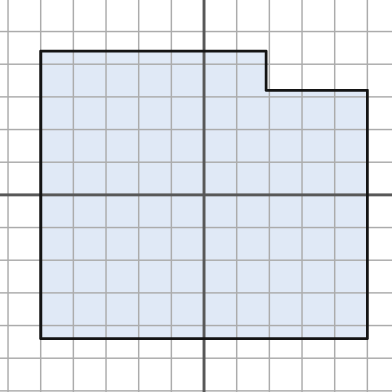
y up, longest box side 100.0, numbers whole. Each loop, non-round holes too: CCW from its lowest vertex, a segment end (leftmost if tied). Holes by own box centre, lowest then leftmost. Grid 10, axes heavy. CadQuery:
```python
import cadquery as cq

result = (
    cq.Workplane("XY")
    .moveTo(-50.0, -44.0)
    .lineTo(50.0, -44.0)
    .lineTo(50.0, 32.0)
    .lineTo(19.0, 32.0)
    .lineTo(19.0, 44.0)
    .lineTo(-50.0, 44.0)
    .close()
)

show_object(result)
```